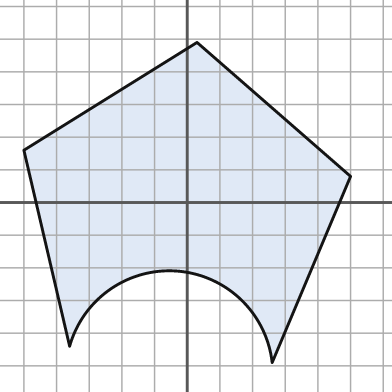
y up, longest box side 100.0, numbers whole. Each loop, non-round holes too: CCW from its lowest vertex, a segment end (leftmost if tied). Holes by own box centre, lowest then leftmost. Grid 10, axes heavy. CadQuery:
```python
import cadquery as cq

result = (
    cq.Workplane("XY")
    .moveTo(26.0, -49.0)
    .lineTo(50.0, 8.0)
    .lineTo(3.0, 49.0)
    .lineTo(-50.0, 16.0)
    .lineTo(-36.0, -44.0)
    .threePointArc((-3.0, -21.0), (26.0, -49.0))
    .close()
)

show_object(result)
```